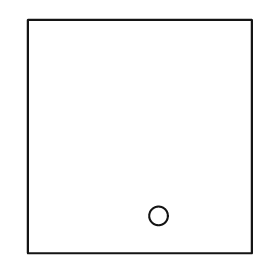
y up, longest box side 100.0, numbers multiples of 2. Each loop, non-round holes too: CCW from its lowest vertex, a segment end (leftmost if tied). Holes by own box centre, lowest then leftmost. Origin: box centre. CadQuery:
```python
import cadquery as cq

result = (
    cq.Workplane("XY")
    .moveTo(-48.0, -50.0)
    .lineTo(48.0, -50.0)
    .lineTo(48.0, 50.0)
    .lineTo(-48.0, 50.0)
    .close()
    .moveTo(8.0, -34.0)
    .circle(4.0)
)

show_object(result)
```